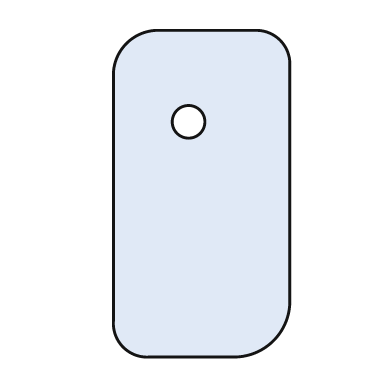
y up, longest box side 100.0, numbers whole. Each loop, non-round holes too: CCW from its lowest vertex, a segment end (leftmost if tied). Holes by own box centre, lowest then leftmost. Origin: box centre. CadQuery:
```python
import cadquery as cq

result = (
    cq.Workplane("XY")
    .moveTo(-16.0, -50.0)
    .lineTo(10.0, -50.0)
    .threePointArc((22.0, -45.0), (27.0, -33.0))
    .lineTo(27.0, 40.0)
    .threePointArc((24.0, 47.0), (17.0, 50.0))
    .lineTo(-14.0, 50.0)
    .threePointArc((-23.0, 46.0), (-27.0, 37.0))
    .lineTo(-27.0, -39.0)
    .threePointArc((-24.0, -47.0), (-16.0, -50.0))
    .close()
    .moveTo(-4.0, 22.0)
    .circle(5.0)
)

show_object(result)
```